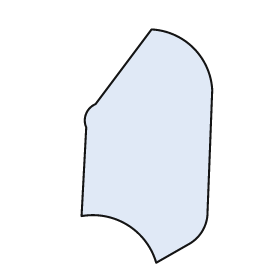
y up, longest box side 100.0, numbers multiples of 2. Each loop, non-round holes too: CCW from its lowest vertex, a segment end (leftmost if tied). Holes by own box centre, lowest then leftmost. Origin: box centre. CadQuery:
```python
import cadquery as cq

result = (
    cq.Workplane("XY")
    .moveTo(4.0, -50.0)
    .lineTo(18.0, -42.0)
    .threePointArc((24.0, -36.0), (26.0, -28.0))
    .lineTo(28.0, 24.0)
    .threePointArc((20.0, 42.0), (2.0, 50.0))
    .lineTo(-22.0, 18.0)
    .threePointArc((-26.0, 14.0), (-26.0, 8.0))
    .lineTo(-28.0, -30.0)
    .threePointArc((-8.0, -34.0), (4.0, -50.0))
    .close()
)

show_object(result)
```